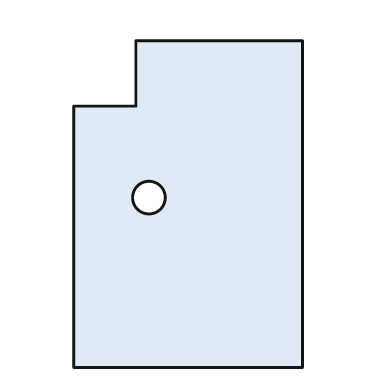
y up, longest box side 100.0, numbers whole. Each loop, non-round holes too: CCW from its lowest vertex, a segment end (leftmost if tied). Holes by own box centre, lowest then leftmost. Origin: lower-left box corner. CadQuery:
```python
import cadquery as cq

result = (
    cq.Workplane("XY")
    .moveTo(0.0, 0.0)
    .lineTo(70.0, 0.0)
    .lineTo(70.0, 100.0)
    .lineTo(19.0, 100.0)
    .lineTo(19.0, 80.0)
    .lineTo(0.0, 80.0)
    .close()
    .moveTo(23.0, 52.0)
    .circle(5.0)
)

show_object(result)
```